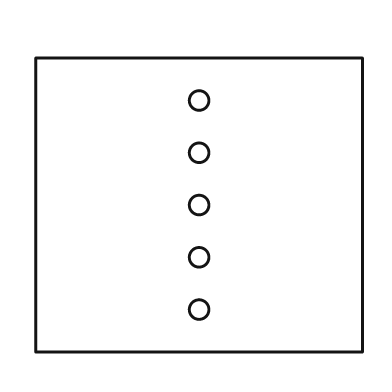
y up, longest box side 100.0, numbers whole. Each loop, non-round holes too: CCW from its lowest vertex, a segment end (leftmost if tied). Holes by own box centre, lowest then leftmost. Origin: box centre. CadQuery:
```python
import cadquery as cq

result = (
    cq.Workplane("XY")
    .moveTo(-50.0, -45.0)
    .lineTo(50.0, -45.0)
    .lineTo(50.0, 45.0)
    .lineTo(-50.0, 45.0)
    .close()
    .moveTo(0.0, -32.0)
    .circle(3.0)
    .moveTo(0.0, -16.0)
    .circle(3.0)
    .moveTo(0.0, 0.0)
    .circle(3.0)
    .moveTo(0.0, 16.0)
    .circle(3.0)
    .moveTo(0.0, 32.0)
    .circle(3.0)
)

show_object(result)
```